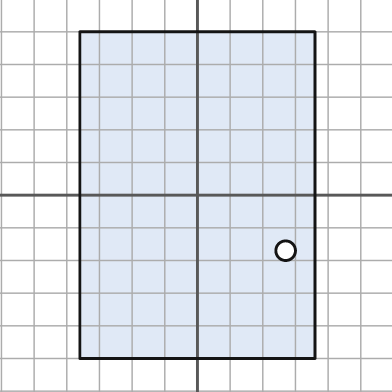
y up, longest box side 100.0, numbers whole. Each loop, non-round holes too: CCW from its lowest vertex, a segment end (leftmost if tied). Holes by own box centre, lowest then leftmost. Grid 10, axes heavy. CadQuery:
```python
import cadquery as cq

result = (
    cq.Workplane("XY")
    .moveTo(-36.0, -50.0)
    .lineTo(36.0, -50.0)
    .lineTo(36.0, 50.0)
    .lineTo(-36.0, 50.0)
    .close()
    .moveTo(27.0, -17.0)
    .circle(3.0)
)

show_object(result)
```